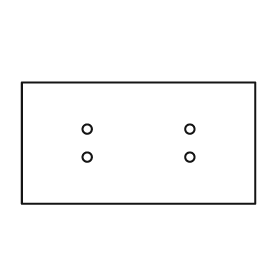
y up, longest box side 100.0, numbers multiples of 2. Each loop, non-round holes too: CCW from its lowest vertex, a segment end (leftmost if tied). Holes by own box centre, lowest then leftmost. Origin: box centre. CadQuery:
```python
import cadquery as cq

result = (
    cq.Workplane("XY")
    .moveTo(-50.0, -26.0)
    .lineTo(50.0, -26.0)
    .lineTo(50.0, 26.0)
    .lineTo(-50.0, 26.0)
    .close()
    .moveTo(-22.0, -6.0)
    .circle(2.0)
    .moveTo(22.0, -6.0)
    .circle(2.0)
    .moveTo(-22.0, 6.0)
    .circle(2.0)
    .moveTo(22.0, 6.0)
    .circle(2.0)
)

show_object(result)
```